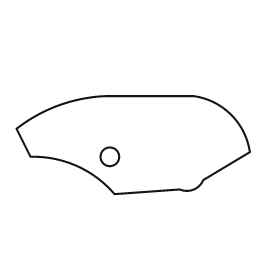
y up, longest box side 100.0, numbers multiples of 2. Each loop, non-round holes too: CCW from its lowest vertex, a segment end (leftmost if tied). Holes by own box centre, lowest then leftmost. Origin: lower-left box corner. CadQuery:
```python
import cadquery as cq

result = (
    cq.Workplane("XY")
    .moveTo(42.0, 0.0)
    .lineTo(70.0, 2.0)
    .threePointArc((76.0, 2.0), (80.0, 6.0))
    .lineTo(100.0, 18.0)
    .threePointArc((92.0, 34.0), (76.0, 42.0))
    .lineTo(38.0, 42.0)
    .threePointArc((18.0, 38.0), (0.0, 28.0))
    .lineTo(6.0, 16.0)
    .threePointArc((26.0, 12.0), (42.0, 0.0))
    .close()
    .moveTo(40.0, 16.0)
    .circle(4.0)
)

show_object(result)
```